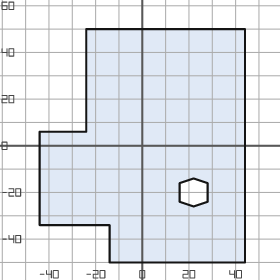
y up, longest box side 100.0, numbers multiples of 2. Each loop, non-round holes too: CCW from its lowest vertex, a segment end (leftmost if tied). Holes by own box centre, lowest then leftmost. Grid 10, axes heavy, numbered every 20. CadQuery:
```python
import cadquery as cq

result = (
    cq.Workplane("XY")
    .moveTo(-14.0, -50.0)
    .lineTo(44.0, -50.0)
    .lineTo(44.0, 50.0)
    .lineTo(-24.0, 50.0)
    .lineTo(-24.0, 6.0)
    .lineTo(-44.0, 6.0)
    .lineTo(-44.0, -34.0)
    .lineTo(-14.0, -34.0)
    .close()
    .moveTo(22.0, -26.0)
    .lineTo(28.0, -24.0)
    .lineTo(28.0, -16.0)
    .lineTo(22.0, -14.0)
    .lineTo(16.0, -16.0)
    .lineTo(16.0, -24.0)
    .close()
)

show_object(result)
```